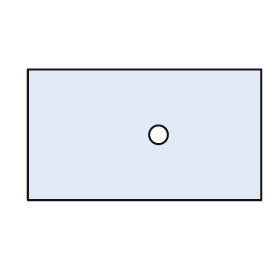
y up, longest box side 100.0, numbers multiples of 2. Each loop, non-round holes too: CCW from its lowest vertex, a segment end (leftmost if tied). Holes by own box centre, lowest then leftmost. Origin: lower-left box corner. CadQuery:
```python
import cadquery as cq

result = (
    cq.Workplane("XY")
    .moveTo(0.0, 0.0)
    .lineTo(100.0, 0.0)
    .lineTo(100.0, 56.0)
    .lineTo(0.0, 56.0)
    .close()
    .moveTo(56.0, 28.0)
    .circle(4.0)
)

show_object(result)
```